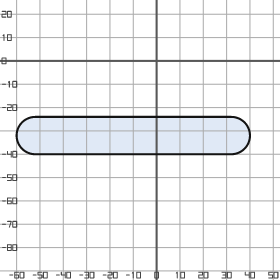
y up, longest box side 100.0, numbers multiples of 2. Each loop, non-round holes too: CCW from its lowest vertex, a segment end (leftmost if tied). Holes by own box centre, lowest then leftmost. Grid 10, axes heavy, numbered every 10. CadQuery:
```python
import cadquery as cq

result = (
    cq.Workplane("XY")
    .moveTo(-52.0, -40.0)
    .lineTo(32.0, -40.0)
    .threePointArc((40.0, -32.0), (32.0, -24.0))
    .lineTo(-52.0, -24.0)
    .threePointArc((-60.0, -32.0), (-52.0, -40.0))
    .close()
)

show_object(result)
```